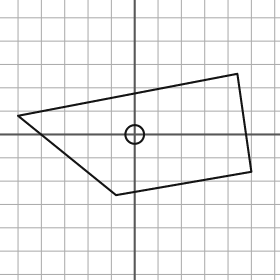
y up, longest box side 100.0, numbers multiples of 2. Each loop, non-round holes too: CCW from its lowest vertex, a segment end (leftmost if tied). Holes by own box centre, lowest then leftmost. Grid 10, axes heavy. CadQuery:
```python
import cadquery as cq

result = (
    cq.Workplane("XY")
    .moveTo(-8.0, -26.0)
    .lineTo(50.0, -16.0)
    .lineTo(44.0, 26.0)
    .lineTo(-50.0, 8.0)
    .close()
    .moveTo(0.0, 0.0)
    .circle(4.0)
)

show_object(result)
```